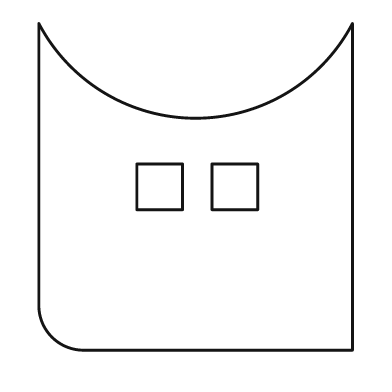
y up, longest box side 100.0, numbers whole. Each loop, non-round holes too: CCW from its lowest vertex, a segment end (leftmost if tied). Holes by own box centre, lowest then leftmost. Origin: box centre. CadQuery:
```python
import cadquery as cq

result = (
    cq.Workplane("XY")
    .moveTo(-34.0, -50.0)
    .lineTo(48.0, -50.0)
    .lineTo(48.0, 50.0)
    .threePointArc((0.0, 21.0), (-48.0, 50.0))
    .lineTo(-48.0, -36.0)
    .threePointArc((-44.0, -46.0), (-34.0, -50.0))
    .close()
    .moveTo(-18.0, -7.0)
    .lineTo(-4.0, -7.0)
    .lineTo(-4.0, 7.0)
    .lineTo(-18.0, 7.0)
    .close()
    .moveTo(5.0, -7.0)
    .lineTo(19.0, -7.0)
    .lineTo(19.0, 7.0)
    .lineTo(5.0, 7.0)
    .close()
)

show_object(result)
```